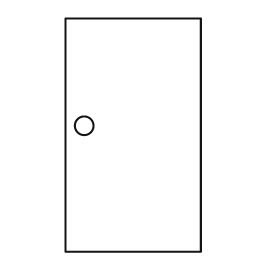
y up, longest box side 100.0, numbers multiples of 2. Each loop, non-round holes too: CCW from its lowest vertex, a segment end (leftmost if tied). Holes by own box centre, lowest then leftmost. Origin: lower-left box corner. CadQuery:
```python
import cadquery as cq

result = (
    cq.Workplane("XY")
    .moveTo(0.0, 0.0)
    .lineTo(58.0, 0.0)
    .lineTo(58.0, 100.0)
    .lineTo(0.0, 100.0)
    .close()
    .moveTo(8.0, 54.0)
    .circle(4.0)
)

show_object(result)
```